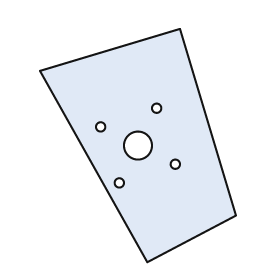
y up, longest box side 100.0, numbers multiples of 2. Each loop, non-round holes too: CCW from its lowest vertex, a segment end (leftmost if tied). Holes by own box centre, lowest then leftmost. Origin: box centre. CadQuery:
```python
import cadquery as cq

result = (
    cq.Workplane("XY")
    .moveTo(4.0, -50.0)
    .lineTo(42.0, -30.0)
    .lineTo(18.0, 50.0)
    .lineTo(-42.0, 32.0)
    .close()
    .moveTo(-8.0, -16.0)
    .circle(2.0)
    .moveTo(16.0, -8.0)
    .circle(2.0)
    .moveTo(0.0, 0.0)
    .circle(6.0)
    .moveTo(-16.0, 8.0)
    .circle(2.0)
    .moveTo(8.0, 16.0)
    .circle(2.0)
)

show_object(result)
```